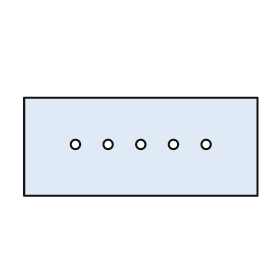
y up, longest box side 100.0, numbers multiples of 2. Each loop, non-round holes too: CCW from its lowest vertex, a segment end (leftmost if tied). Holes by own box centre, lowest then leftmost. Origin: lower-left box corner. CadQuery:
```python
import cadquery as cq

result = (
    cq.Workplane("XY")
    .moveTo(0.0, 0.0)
    .lineTo(100.0, 0.0)
    .lineTo(100.0, 42.0)
    .lineTo(0.0, 42.0)
    .close()
    .moveTo(22.0, 22.0)
    .circle(2.0)
    .moveTo(36.0, 22.0)
    .circle(2.0)
    .moveTo(50.0, 22.0)
    .circle(2.0)
    .moveTo(64.0, 22.0)
    .circle(2.0)
    .moveTo(78.0, 22.0)
    .circle(2.0)
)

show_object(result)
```